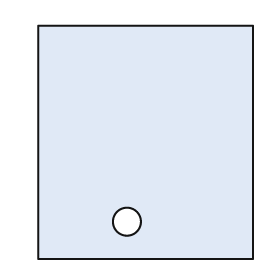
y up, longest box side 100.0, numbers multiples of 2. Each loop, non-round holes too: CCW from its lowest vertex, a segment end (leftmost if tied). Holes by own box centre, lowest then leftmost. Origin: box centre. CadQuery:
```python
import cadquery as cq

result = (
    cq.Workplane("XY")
    .moveTo(-46.0, -50.0)
    .lineTo(46.0, -50.0)
    .lineTo(46.0, 50.0)
    .lineTo(-46.0, 50.0)
    .close()
    .moveTo(-8.0, -34.0)
    .circle(6.0)
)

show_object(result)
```